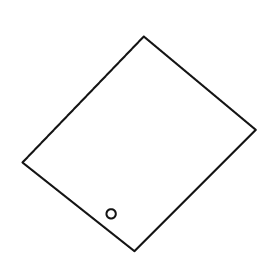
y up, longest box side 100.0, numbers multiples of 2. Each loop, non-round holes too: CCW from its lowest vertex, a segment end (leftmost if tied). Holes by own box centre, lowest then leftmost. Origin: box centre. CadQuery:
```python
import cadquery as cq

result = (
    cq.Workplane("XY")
    .moveTo(-2.0, -46.0)
    .lineTo(50.0, 6.0)
    .lineTo(2.0, 46.0)
    .lineTo(-50.0, -8.0)
    .close()
    .moveTo(-12.0, -30.0)
    .circle(2.0)
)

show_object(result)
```